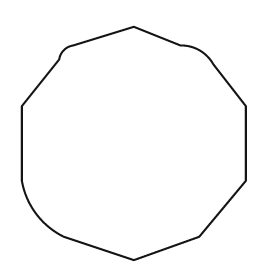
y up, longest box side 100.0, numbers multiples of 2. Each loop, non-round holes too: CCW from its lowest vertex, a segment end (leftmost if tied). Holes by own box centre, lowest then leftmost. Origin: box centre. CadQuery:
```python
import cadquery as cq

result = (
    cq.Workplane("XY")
    .moveTo(0.0, -50.0)
    .lineTo(28.0, -40.0)
    .lineTo(48.0, -16.0)
    .lineTo(48.0, 16.0)
    .lineTo(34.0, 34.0)
    .threePointArc((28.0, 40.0), (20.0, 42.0))
    .lineTo(0.0, 50.0)
    .lineTo(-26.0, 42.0)
    .threePointArc((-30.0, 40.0), (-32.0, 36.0))
    .lineTo(-48.0, 16.0)
    .lineTo(-48.0, -16.0)
    .threePointArc((-42.0, -30.0), (-30.0, -40.0))
    .close()
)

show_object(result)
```